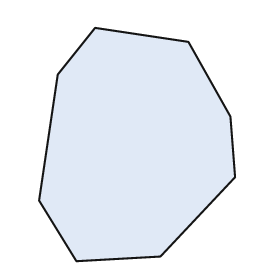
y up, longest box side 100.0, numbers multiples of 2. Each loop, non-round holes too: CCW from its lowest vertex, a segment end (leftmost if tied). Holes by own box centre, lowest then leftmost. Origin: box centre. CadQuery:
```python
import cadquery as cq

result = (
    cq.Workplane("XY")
    .moveTo(-26.0, -50.0)
    .lineTo(10.0, -48.0)
    .lineTo(42.0, -14.0)
    .lineTo(40.0, 12.0)
    .lineTo(22.0, 44.0)
    .lineTo(-18.0, 50.0)
    .lineTo(-34.0, 30.0)
    .lineTo(-42.0, -24.0)
    .close()
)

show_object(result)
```